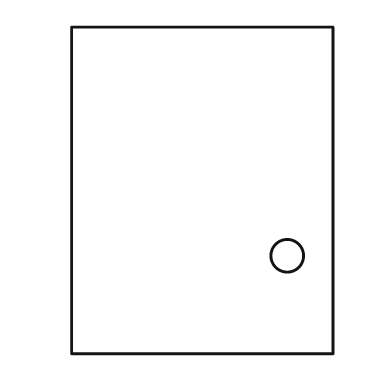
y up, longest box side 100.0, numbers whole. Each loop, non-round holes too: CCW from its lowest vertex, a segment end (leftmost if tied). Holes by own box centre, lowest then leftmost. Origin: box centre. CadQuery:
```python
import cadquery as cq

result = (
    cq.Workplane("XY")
    .moveTo(-40.0, -50.0)
    .lineTo(40.0, -50.0)
    .lineTo(40.0, 50.0)
    .lineTo(-40.0, 50.0)
    .close()
    .moveTo(26.0, -20.0)
    .circle(5.0)
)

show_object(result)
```